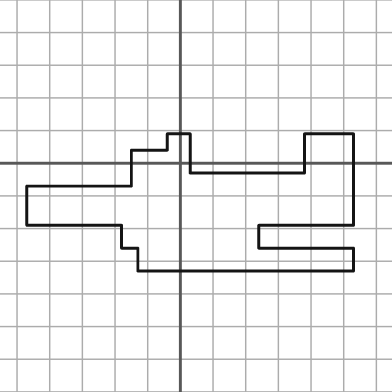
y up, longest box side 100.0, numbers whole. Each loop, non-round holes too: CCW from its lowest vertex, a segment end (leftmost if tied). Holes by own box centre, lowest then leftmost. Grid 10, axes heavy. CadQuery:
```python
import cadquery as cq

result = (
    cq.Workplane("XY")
    .moveTo(-13.0, -33.0)
    .lineTo(53.0, -33.0)
    .lineTo(53.0, -26.0)
    .lineTo(24.0, -26.0)
    .lineTo(24.0, -19.0)
    .lineTo(53.0, -19.0)
    .lineTo(53.0, 9.0)
    .lineTo(38.0, 9.0)
    .lineTo(38.0, -3.0)
    .lineTo(3.0, -3.0)
    .lineTo(3.0, 9.0)
    .lineTo(-4.0, 9.0)
    .lineTo(-4.0, 4.0)
    .lineTo(-15.0, 4.0)
    .lineTo(-15.0, -7.0)
    .lineTo(-47.0, -7.0)
    .lineTo(-47.0, -19.0)
    .lineTo(-18.0, -19.0)
    .lineTo(-18.0, -26.0)
    .lineTo(-13.0, -26.0)
    .close()
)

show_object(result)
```